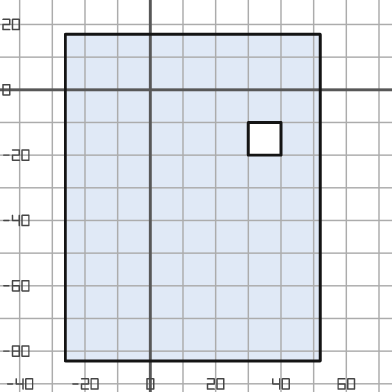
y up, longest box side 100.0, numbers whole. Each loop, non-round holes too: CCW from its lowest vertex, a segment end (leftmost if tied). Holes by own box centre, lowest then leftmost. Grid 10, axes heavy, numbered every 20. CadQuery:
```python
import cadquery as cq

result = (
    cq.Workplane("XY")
    .moveTo(-26.0, -83.0)
    .lineTo(52.0, -83.0)
    .lineTo(52.0, 17.0)
    .lineTo(-26.0, 17.0)
    .close()
    .moveTo(30.0, -20.0)
    .lineTo(40.0, -20.0)
    .lineTo(40.0, -10.0)
    .lineTo(30.0, -10.0)
    .close()
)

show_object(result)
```